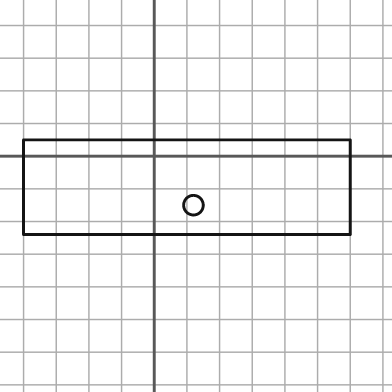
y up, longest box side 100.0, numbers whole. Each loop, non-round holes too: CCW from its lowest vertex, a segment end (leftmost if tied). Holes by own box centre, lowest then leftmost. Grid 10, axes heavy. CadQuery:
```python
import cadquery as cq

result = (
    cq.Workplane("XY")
    .moveTo(-40.0, -24.0)
    .lineTo(60.0, -24.0)
    .lineTo(60.0, 5.0)
    .lineTo(-40.0, 5.0)
    .close()
    .moveTo(12.0, -15.0)
    .circle(3.0)
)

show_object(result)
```